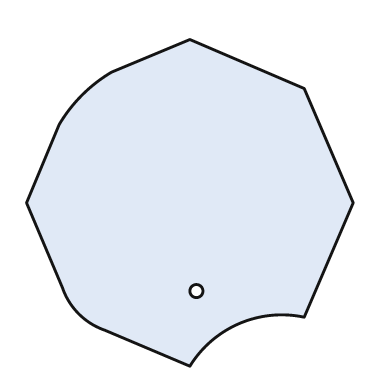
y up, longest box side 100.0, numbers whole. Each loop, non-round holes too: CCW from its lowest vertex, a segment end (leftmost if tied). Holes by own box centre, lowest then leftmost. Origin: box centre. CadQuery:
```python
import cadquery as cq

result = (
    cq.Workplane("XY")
    .moveTo(0.0, -50.0)
    .threePointArc((15.0, -37.0), (35.0, -35.0))
    .lineTo(50.0, 0.0)
    .lineTo(35.0, 35.0)
    .lineTo(0.0, 50.0)
    .lineTo(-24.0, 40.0)
    .threePointArc((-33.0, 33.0), (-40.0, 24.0))
    .lineTo(-50.0, 0.0)
    .lineTo(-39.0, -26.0)
    .threePointArc((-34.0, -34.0), (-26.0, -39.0))
    .close()
    .moveTo(2.0, -27.0)
    .circle(2.0)
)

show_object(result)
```